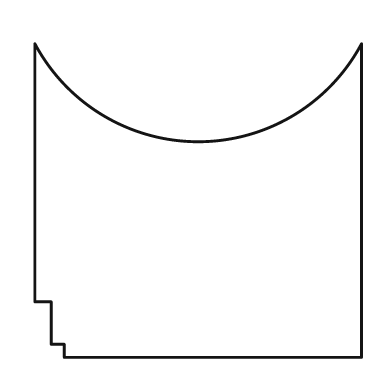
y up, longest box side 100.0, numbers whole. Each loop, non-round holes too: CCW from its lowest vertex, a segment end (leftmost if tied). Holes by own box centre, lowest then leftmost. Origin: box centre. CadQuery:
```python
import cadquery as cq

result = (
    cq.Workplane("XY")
    .moveTo(-41.0, -48.0)
    .lineTo(50.0, -48.0)
    .lineTo(50.0, 48.0)
    .threePointArc((0.0, 18.0), (-50.0, 48.0))
    .lineTo(-50.0, -31.0)
    .lineTo(-45.0, -31.0)
    .lineTo(-45.0, -44.0)
    .lineTo(-41.0, -44.0)
    .close()
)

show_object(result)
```